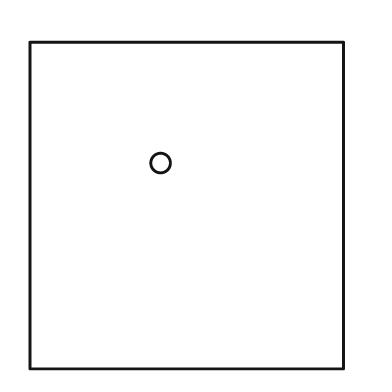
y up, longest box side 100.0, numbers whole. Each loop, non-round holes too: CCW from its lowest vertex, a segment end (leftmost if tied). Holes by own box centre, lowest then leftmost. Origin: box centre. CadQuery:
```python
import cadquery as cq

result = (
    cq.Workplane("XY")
    .moveTo(-48.0, -50.0)
    .lineTo(48.0, -50.0)
    .lineTo(48.0, 50.0)
    .lineTo(-48.0, 50.0)
    .close()
    .moveTo(-8.0, 13.0)
    .circle(3.0)
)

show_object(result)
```